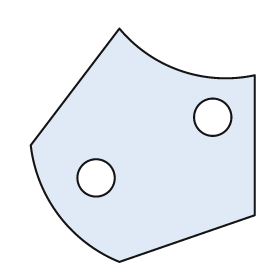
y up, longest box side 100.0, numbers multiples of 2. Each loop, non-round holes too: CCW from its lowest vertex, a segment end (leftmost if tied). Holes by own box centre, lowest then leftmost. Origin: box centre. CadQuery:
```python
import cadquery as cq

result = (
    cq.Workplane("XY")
    .moveTo(-10.0, -50.0)
    .lineTo(48.0, -30.0)
    .lineTo(48.0, 30.0)
    .threePointArc((16.0, 32.0), (-10.0, 50.0))
    .lineTo(-48.0, 0.0)
    .threePointArc((-36.0, -30.0), (-10.0, -50.0))
    .close()
    .moveTo(-20.0, -14.0)
    .circle(8.0)
    .moveTo(30.0, 12.0)
    .circle(8.0)
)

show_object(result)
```